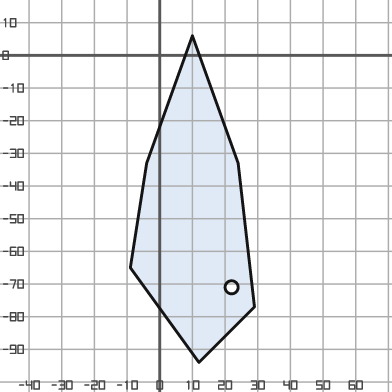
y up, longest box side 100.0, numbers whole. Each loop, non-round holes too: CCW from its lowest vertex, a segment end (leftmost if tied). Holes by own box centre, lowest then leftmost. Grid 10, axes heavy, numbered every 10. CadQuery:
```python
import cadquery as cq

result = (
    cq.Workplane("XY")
    .moveTo(12.0, -94.0)
    .lineTo(29.0, -77.0)
    .lineTo(24.0, -33.0)
    .lineTo(10.0, 6.0)
    .lineTo(-4.0, -33.0)
    .lineTo(-9.0, -65.0)
    .close()
    .moveTo(22.0, -71.0)
    .circle(2.0)
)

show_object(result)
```